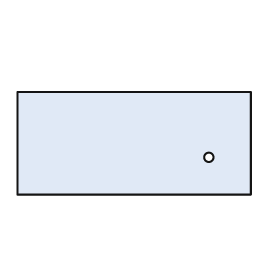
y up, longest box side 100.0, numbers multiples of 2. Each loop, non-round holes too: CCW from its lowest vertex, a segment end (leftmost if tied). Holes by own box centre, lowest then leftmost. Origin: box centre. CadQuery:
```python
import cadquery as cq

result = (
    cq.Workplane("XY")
    .moveTo(-50.0, -22.0)
    .lineTo(50.0, -22.0)
    .lineTo(50.0, 22.0)
    .lineTo(-50.0, 22.0)
    .close()
    .moveTo(32.0, -6.0)
    .circle(2.0)
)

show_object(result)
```